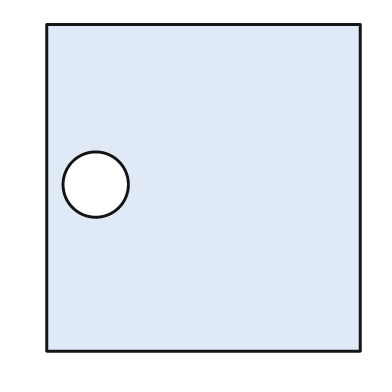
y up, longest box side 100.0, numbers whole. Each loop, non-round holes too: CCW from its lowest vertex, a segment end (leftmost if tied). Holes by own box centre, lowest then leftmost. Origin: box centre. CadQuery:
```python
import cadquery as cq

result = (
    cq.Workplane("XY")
    .moveTo(-48.0, -50.0)
    .lineTo(48.0, -50.0)
    .lineTo(48.0, 50.0)
    .lineTo(-48.0, 50.0)
    .close()
    .moveTo(-33.0, 1.0)
    .circle(10.0)
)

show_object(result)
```